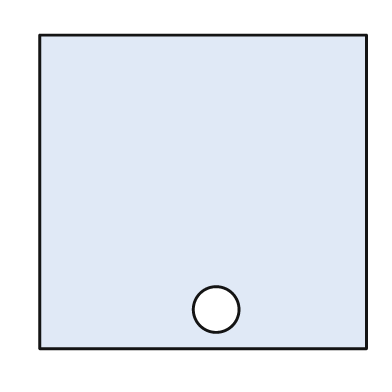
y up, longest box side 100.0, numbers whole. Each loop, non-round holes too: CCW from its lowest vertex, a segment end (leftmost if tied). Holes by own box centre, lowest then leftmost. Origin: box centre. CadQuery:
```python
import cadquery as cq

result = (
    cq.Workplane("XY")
    .moveTo(-50.0, -48.0)
    .lineTo(50.0, -48.0)
    .lineTo(50.0, 48.0)
    .lineTo(-50.0, 48.0)
    .close()
    .moveTo(4.0, -36.0)
    .circle(7.0)
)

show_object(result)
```